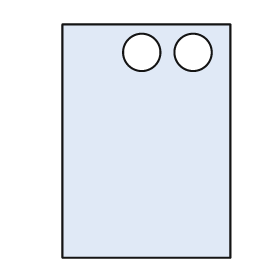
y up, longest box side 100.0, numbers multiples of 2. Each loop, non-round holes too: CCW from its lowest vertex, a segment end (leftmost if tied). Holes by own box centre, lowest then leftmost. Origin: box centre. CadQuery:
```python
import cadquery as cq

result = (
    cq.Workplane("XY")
    .moveTo(-36.0, -50.0)
    .lineTo(36.0, -50.0)
    .lineTo(36.0, 50.0)
    .lineTo(-36.0, 50.0)
    .close()
    .moveTo(-2.0, 38.0)
    .circle(8.0)
    .moveTo(20.0, 38.0)
    .circle(8.0)
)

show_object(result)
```